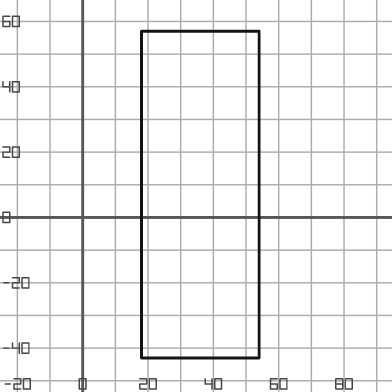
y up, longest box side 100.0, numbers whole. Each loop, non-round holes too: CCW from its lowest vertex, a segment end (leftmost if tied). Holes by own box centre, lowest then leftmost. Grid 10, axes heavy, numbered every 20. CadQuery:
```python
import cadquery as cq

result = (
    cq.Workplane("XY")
    .moveTo(18.0, -43.0)
    .lineTo(54.0, -43.0)
    .lineTo(54.0, 57.0)
    .lineTo(18.0, 57.0)
    .close()
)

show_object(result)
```